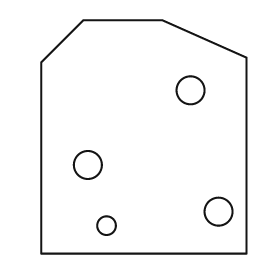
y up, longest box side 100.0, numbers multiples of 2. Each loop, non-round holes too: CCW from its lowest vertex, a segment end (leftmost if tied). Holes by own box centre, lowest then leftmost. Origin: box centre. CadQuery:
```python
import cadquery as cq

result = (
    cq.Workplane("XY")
    .moveTo(-44.0, -50.0)
    .lineTo(44.0, -50.0)
    .lineTo(44.0, 34.0)
    .lineTo(8.0, 50.0)
    .lineTo(-26.0, 50.0)
    .lineTo(-44.0, 32.0)
    .close()
    .moveTo(-16.0, -38.0)
    .circle(4.0)
    .moveTo(32.0, -32.0)
    .circle(6.0)
    .moveTo(-24.0, -12.0)
    .circle(6.0)
    .moveTo(20.0, 20.0)
    .circle(6.0)
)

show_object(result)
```